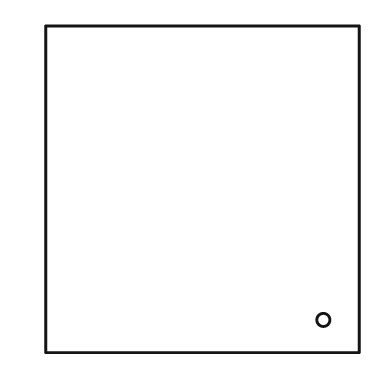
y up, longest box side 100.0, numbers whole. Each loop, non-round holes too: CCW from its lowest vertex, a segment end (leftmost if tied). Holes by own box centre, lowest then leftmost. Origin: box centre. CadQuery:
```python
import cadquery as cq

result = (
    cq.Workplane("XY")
    .moveTo(-48.0, -50.0)
    .lineTo(48.0, -50.0)
    .lineTo(48.0, 50.0)
    .lineTo(-48.0, 50.0)
    .close()
    .moveTo(37.0, -40.0)
    .circle(2.0)
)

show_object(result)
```